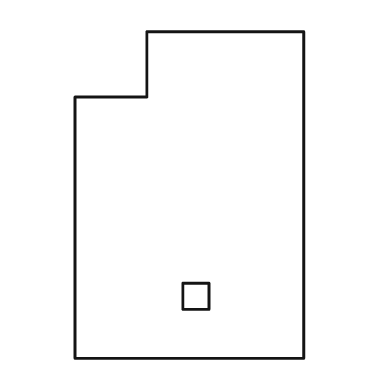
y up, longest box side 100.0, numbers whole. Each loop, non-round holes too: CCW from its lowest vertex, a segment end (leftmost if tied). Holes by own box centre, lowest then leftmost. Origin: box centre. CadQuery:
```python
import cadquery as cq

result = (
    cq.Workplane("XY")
    .moveTo(-35.0, -50.0)
    .lineTo(35.0, -50.0)
    .lineTo(35.0, 50.0)
    .lineTo(-13.0, 50.0)
    .lineTo(-13.0, 30.0)
    .lineTo(-35.0, 30.0)
    .close()
    .moveTo(-2.0, -35.0)
    .lineTo(6.0, -35.0)
    .lineTo(6.0, -27.0)
    .lineTo(-2.0, -27.0)
    .close()
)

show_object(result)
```